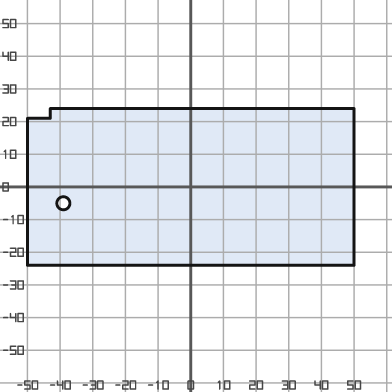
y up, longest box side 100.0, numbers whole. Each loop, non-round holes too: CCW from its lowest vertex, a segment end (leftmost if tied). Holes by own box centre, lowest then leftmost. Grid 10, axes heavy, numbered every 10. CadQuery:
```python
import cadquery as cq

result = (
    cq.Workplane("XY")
    .moveTo(-50.0, -24.0)
    .lineTo(50.0, -24.0)
    .lineTo(50.0, 24.0)
    .lineTo(-43.0, 24.0)
    .lineTo(-43.0, 21.0)
    .lineTo(-50.0, 21.0)
    .close()
    .moveTo(-39.0, -5.0)
    .circle(2.0)
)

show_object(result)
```